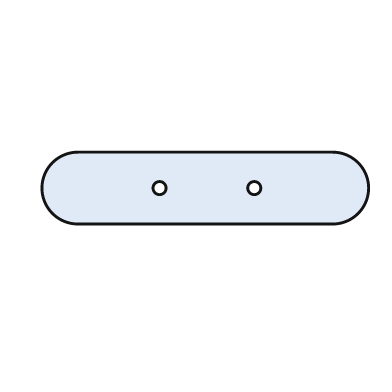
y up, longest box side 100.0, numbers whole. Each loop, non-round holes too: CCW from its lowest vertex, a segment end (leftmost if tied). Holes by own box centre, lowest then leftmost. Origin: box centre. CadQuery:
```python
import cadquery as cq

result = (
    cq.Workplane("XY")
    .moveTo(-39.0, -11.0)
    .lineTo(39.0, -11.0)
    .threePointArc((50.0, 0.0), (39.0, 11.0))
    .lineTo(-39.0, 11.0)
    .threePointArc((-50.0, 0.0), (-39.0, -11.0))
    .close()
    .moveTo(-14.0, 0.0)
    .circle(2.0)
    .moveTo(15.0, 0.0)
    .circle(2.0)
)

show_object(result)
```